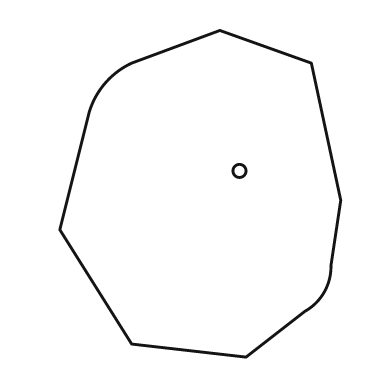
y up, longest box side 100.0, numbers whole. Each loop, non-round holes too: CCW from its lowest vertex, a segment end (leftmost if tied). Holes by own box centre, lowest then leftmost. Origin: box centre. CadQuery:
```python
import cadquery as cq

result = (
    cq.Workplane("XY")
    .moveTo(14.0, -50.0)
    .lineTo(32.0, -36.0)
    .threePointArc((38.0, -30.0), (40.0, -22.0))
    .lineTo(43.0, -2.0)
    .lineTo(34.0, 40.0)
    .lineTo(6.0, 50.0)
    .lineTo(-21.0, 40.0)
    .threePointArc((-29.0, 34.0), (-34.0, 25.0))
    .lineTo(-43.0, -11.0)
    .lineTo(-21.0, -46.0)
    .close()
    .moveTo(12.0, 7.0)
    .circle(2.0)
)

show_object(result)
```